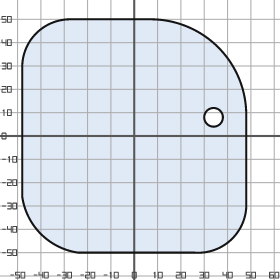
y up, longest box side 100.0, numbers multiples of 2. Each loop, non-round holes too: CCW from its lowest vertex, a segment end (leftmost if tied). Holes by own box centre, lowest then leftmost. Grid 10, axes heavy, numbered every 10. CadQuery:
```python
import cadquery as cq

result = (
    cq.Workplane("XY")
    .moveTo(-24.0, -50.0)
    .lineTo(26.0, -50.0)
    .threePointArc((42.0, -44.0), (48.0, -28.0))
    .lineTo(48.0, 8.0)
    .threePointArc((36.0, 38.0), (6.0, 50.0))
    .lineTo(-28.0, 50.0)
    .threePointArc((-42.0, 44.0), (-48.0, 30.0))
    .lineTo(-48.0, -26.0)
    .threePointArc((-40.0, -42.0), (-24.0, -50.0))
    .close()
    .moveTo(34.0, 8.0)
    .circle(4.0)
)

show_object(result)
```